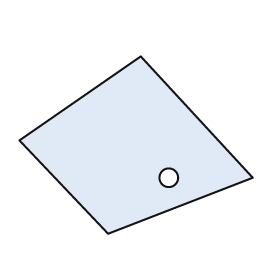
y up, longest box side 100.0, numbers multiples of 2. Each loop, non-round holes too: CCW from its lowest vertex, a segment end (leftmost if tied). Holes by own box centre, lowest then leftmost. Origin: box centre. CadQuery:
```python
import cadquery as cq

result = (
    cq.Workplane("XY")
    .moveTo(-12.0, -38.0)
    .lineTo(50.0, -14.0)
    .lineTo(2.0, 38.0)
    .lineTo(-50.0, 2.0)
    .close()
    .moveTo(14.0, -14.0)
    .circle(4.0)
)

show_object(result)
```